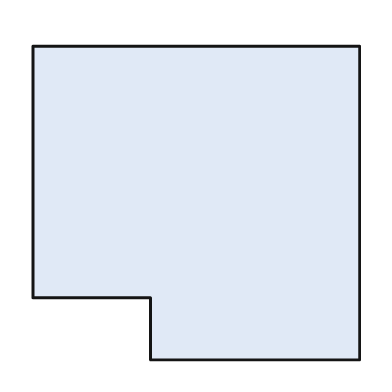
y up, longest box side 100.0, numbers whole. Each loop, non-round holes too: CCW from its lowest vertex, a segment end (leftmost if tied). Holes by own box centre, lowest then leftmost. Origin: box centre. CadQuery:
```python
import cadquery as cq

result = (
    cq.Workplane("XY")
    .moveTo(-14.0, -48.0)
    .lineTo(50.0, -48.0)
    .lineTo(50.0, 48.0)
    .lineTo(-50.0, 48.0)
    .lineTo(-50.0, -29.0)
    .lineTo(-14.0, -29.0)
    .close()
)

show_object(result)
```